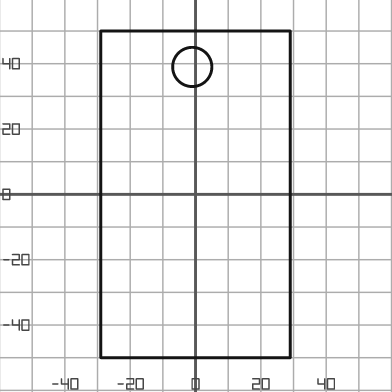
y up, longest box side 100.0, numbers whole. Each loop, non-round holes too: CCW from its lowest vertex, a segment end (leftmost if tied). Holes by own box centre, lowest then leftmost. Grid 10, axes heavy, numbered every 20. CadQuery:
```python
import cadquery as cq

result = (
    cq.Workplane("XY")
    .moveTo(-29.0, -50.0)
    .lineTo(29.0, -50.0)
    .lineTo(29.0, 50.0)
    .lineTo(-29.0, 50.0)
    .close()
    .moveTo(-1.0, 39.0)
    .circle(6.0)
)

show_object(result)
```